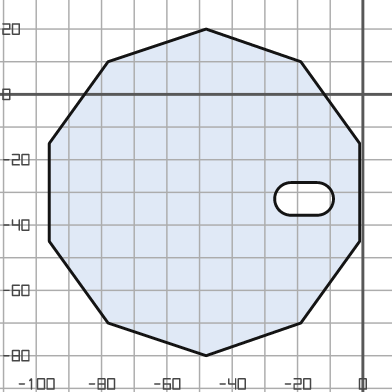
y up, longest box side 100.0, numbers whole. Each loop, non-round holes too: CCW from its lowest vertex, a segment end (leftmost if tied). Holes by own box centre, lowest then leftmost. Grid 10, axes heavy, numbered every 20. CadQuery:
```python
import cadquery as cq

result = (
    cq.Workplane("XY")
    .moveTo(-48.0, -80.0)
    .lineTo(-19.0, -70.0)
    .lineTo(-1.0, -45.0)
    .lineTo(-1.0, -15.0)
    .lineTo(-19.0, 10.0)
    .lineTo(-48.0, 20.0)
    .lineTo(-78.0, 10.0)
    .lineTo(-96.0, -15.0)
    .lineTo(-96.0, -45.0)
    .lineTo(-78.0, -70.0)
    .close()
    .moveTo(-22.0, -37.0)
    .lineTo(-14.0, -37.0)
    .threePointArc((-9.0, -32.0), (-14.0, -27.0))
    .lineTo(-22.0, -27.0)
    .threePointArc((-27.0, -32.0), (-22.0, -37.0))
    .close()
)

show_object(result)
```